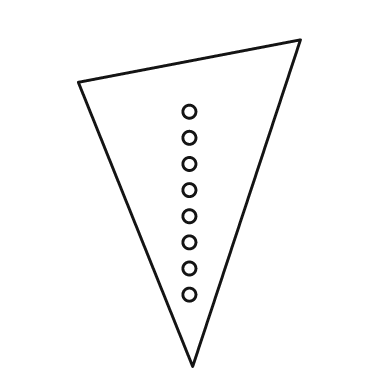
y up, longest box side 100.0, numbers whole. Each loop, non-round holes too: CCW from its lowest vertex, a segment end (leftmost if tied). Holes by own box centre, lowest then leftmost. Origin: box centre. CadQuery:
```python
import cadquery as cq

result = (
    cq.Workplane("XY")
    .moveTo(1.0, -50.0)
    .lineTo(34.0, 50.0)
    .lineTo(-34.0, 37.0)
    .close()
    .moveTo(0.0, -28.0)
    .circle(2.0)
    .moveTo(0.0, -20.0)
    .circle(2.0)
    .moveTo(0.0, -12.0)
    .circle(2.0)
    .moveTo(0.0, -4.0)
    .circle(2.0)
    .moveTo(0.0, 4.0)
    .circle(2.0)
    .moveTo(0.0, 12.0)
    .circle(2.0)
    .moveTo(0.0, 20.0)
    .circle(2.0)
    .moveTo(0.0, 28.0)
    .circle(2.0)
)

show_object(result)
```